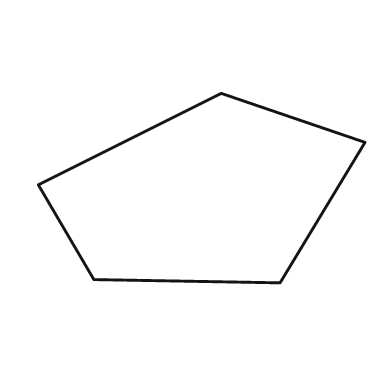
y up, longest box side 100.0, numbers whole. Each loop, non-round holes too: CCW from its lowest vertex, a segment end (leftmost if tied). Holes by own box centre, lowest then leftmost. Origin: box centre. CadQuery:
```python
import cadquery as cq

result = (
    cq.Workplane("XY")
    .moveTo(24.0, -29.0)
    .lineTo(50.0, 14.0)
    .lineTo(6.0, 29.0)
    .lineTo(-50.0, 1.0)
    .lineTo(-33.0, -28.0)
    .close()
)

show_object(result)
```